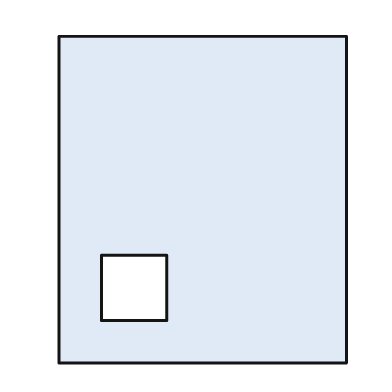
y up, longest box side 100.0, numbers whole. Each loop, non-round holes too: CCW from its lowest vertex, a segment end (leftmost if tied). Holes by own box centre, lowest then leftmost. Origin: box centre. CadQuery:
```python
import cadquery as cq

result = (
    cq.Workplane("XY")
    .moveTo(-44.0, -50.0)
    .lineTo(44.0, -50.0)
    .lineTo(44.0, 50.0)
    .lineTo(-44.0, 50.0)
    .close()
    .moveTo(-31.0, -37.0)
    .lineTo(-11.0, -37.0)
    .lineTo(-11.0, -17.0)
    .lineTo(-31.0, -17.0)
    .close()
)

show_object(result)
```